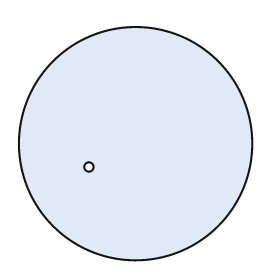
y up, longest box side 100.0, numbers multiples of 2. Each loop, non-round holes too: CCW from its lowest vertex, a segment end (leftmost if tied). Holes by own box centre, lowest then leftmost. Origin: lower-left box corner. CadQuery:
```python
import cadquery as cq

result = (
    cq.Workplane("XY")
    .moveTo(50.0, 50.0)
    .circle(50.0)
    .moveTo(30.0, 40.0)
    .circle(2.0)
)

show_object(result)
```